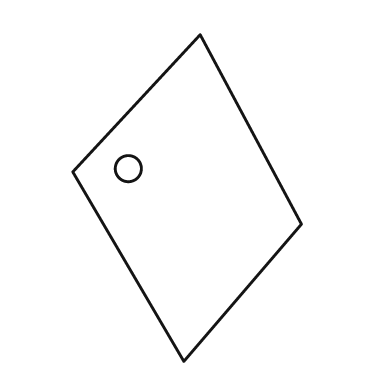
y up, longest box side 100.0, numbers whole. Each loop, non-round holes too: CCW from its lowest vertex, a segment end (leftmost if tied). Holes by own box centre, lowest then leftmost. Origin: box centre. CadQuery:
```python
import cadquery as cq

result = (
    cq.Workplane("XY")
    .moveTo(-1.0, -50.0)
    .lineTo(35.0, -8.0)
    .lineTo(4.0, 50.0)
    .lineTo(-35.0, 8.0)
    .close()
    .moveTo(-18.0, 9.0)
    .circle(4.0)
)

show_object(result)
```